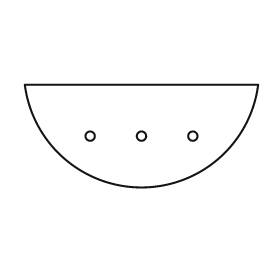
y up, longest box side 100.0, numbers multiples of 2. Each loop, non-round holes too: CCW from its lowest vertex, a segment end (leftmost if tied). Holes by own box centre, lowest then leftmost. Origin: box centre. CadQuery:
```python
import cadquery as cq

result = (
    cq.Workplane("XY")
    .moveTo(-50.0, 22.0)
    .threePointArc((0.0, -22.0), (50.0, 22.0))
    .close()
    .moveTo(-22.0, 0.0)
    .circle(2.0)
    .moveTo(0.0, 0.0)
    .circle(2.0)
    .moveTo(22.0, 0.0)
    .circle(2.0)
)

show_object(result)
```